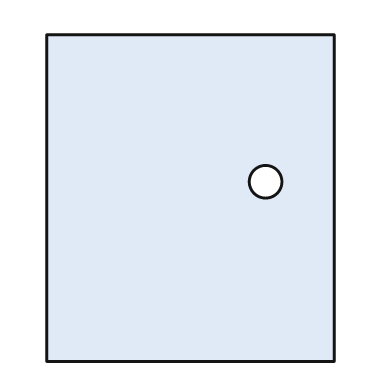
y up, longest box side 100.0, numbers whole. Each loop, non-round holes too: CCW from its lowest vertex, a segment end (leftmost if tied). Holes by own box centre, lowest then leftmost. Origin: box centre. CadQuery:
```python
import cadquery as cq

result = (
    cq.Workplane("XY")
    .moveTo(-44.0, -50.0)
    .lineTo(44.0, -50.0)
    .lineTo(44.0, 50.0)
    .lineTo(-44.0, 50.0)
    .close()
    .moveTo(23.0, 5.0)
    .circle(5.0)
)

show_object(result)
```